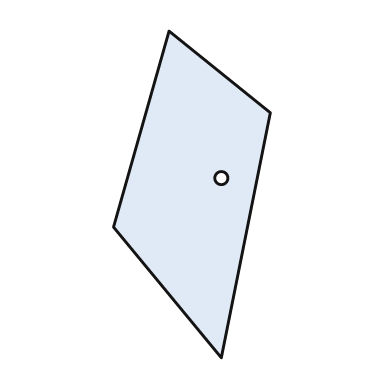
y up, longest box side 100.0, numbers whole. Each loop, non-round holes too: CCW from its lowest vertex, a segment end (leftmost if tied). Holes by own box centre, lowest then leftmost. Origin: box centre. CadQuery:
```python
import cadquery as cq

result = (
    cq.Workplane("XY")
    .moveTo(9.0, -50.0)
    .lineTo(24.0, 25.0)
    .lineTo(-7.0, 50.0)
    .lineTo(-24.0, -10.0)
    .close()
    .moveTo(9.0, 5.0)
    .circle(2.0)
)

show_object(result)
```